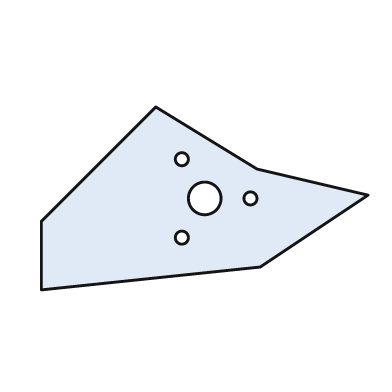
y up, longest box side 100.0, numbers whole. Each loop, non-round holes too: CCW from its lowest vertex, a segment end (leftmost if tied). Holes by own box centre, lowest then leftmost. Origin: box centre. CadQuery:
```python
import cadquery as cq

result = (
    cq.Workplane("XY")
    .moveTo(-50.0, -28.0)
    .lineTo(17.0, -21.0)
    .lineTo(50.0, 1.0)
    .lineTo(16.0, 9.0)
    .lineTo(-15.0, 28.0)
    .lineTo(-50.0, -7.0)
    .close()
    .moveTo(-7.0, -12.0)
    .circle(2.0)
    .moveTo(0.0, 0.0)
    .circle(5.0)
    .moveTo(14.0, 0.0)
    .circle(2.0)
    .moveTo(-7.0, 12.0)
    .circle(2.0)
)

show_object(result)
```